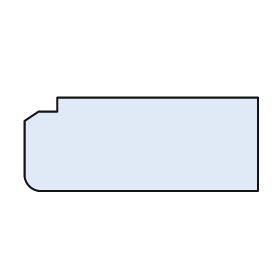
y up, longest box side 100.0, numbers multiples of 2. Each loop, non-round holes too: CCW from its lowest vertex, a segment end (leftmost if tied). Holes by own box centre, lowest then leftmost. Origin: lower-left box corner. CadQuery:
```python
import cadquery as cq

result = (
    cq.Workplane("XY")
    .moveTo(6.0, 0.0)
    .lineTo(100.0, 0.0)
    .lineTo(100.0, 40.0)
    .lineTo(14.0, 40.0)
    .lineTo(14.0, 34.0)
    .lineTo(6.0, 34.0)
    .lineTo(0.0, 30.0)
    .lineTo(0.0, 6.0)
    .threePointArc((2.0, 2.0), (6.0, 0.0))
    .close()
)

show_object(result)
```